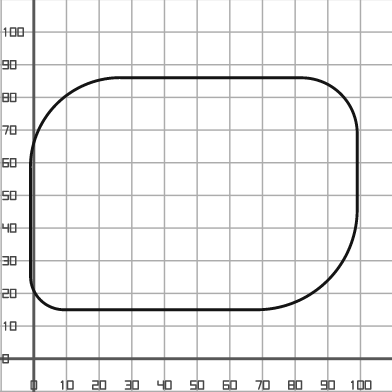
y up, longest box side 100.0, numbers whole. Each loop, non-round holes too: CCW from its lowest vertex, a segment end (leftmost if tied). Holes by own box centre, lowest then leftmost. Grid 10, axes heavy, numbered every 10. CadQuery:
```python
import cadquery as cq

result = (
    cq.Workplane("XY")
    .moveTo(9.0, 15.0)
    .lineTo(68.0, 15.0)
    .threePointArc((90.0, 24.0), (99.0, 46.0))
    .lineTo(99.0, 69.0)
    .threePointArc((94.0, 81.0), (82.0, 86.0))
    .lineTo(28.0, 86.0)
    .threePointArc((7.0, 78.0), (-1.0, 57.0))
    .lineTo(-1.0, 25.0)
    .threePointArc((2.0, 18.0), (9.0, 15.0))
    .close()
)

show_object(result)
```